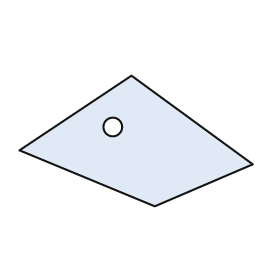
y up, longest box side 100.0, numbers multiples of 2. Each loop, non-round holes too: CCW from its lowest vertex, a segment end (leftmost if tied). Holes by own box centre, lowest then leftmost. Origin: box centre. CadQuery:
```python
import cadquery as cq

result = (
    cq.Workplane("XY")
    .moveTo(8.0, -28.0)
    .lineTo(50.0, -10.0)
    .lineTo(-2.0, 28.0)
    .lineTo(-50.0, -4.0)
    .close()
    .moveTo(-10.0, 6.0)
    .circle(4.0)
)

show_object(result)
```